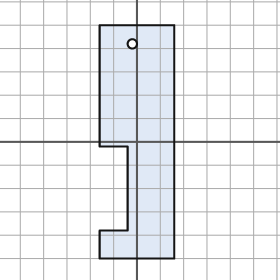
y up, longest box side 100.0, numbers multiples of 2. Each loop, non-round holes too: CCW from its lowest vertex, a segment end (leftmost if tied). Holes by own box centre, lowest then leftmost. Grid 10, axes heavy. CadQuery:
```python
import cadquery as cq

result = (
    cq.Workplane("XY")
    .moveTo(-16.0, -50.0)
    .lineTo(16.0, -50.0)
    .lineTo(16.0, 50.0)
    .lineTo(-16.0, 50.0)
    .lineTo(-16.0, -2.0)
    .lineTo(-4.0, -2.0)
    .lineTo(-4.0, -38.0)
    .lineTo(-16.0, -38.0)
    .close()
    .moveTo(-2.0, 42.0)
    .circle(2.0)
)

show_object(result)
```